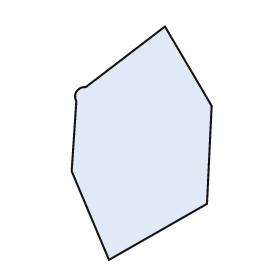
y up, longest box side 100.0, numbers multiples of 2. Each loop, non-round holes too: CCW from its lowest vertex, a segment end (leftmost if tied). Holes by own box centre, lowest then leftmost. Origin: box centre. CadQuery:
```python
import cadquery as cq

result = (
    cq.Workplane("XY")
    .moveTo(-14.0, -50.0)
    .lineTo(28.0, -26.0)
    .lineTo(30.0, 16.0)
    .lineTo(10.0, 50.0)
    .lineTo(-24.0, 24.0)
    .threePointArc((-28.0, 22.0), (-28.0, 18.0))
    .lineTo(-30.0, -12.0)
    .close()
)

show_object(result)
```